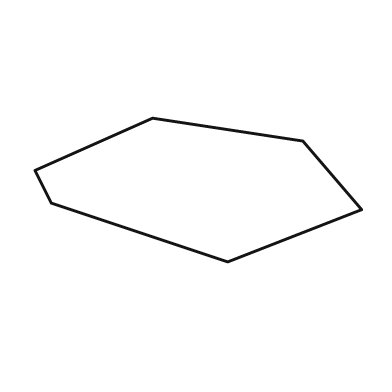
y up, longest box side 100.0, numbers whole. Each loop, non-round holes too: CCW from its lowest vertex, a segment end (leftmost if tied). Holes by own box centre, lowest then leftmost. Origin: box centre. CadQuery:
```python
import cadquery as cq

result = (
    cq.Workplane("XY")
    .moveTo(9.0, -22.0)
    .lineTo(50.0, -6.0)
    .lineTo(32.0, 15.0)
    .lineTo(-14.0, 22.0)
    .lineTo(-50.0, 6.0)
    .lineTo(-45.0, -4.0)
    .close()
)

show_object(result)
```